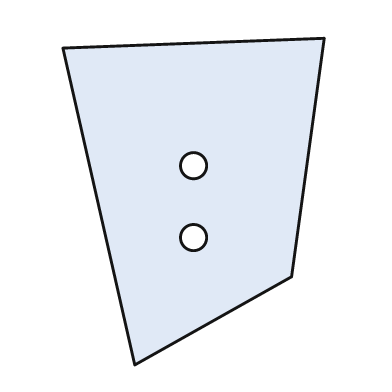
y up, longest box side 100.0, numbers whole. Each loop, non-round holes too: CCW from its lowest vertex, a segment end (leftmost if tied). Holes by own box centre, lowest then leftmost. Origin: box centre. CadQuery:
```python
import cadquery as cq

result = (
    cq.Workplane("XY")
    .moveTo(-18.0, -50.0)
    .lineTo(30.0, -23.0)
    .lineTo(40.0, 50.0)
    .lineTo(-40.0, 47.0)
    .close()
    .moveTo(0.0, -11.0)
    .circle(4.0)
    .moveTo(0.0, 11.0)
    .circle(4.0)
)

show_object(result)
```